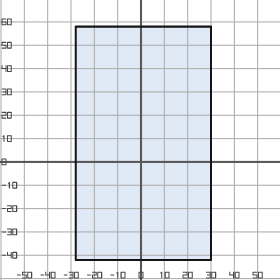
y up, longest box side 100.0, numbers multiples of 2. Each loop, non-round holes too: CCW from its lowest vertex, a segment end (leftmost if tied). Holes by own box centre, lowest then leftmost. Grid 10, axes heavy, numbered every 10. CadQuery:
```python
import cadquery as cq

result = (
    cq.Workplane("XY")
    .moveTo(-28.0, -42.0)
    .lineTo(30.0, -42.0)
    .lineTo(30.0, 58.0)
    .lineTo(-28.0, 58.0)
    .close()
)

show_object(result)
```